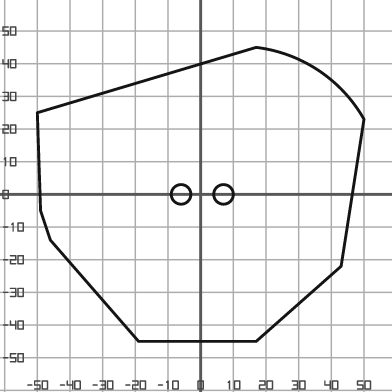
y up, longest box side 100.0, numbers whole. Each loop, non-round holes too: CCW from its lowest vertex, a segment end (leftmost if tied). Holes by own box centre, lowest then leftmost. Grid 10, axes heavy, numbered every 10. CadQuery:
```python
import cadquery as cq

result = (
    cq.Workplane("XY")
    .moveTo(-19.0, -45.0)
    .lineTo(17.0, -45.0)
    .lineTo(43.0, -22.0)
    .lineTo(50.0, 23.0)
    .threePointArc((36.0, 38.0), (17.0, 45.0))
    .lineTo(-50.0, 25.0)
    .lineTo(-49.0, -5.0)
    .lineTo(-46.0, -14.0)
    .close()
    .moveTo(-6.0, 0.0)
    .circle(3.0)
    .moveTo(7.0, 0.0)
    .circle(3.0)
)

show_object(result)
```